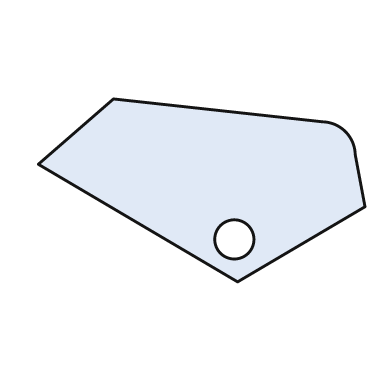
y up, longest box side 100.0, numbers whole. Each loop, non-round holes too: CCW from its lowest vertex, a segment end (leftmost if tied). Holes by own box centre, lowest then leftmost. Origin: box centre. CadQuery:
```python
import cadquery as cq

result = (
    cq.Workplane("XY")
    .moveTo(11.0, -28.0)
    .lineTo(50.0, -5.0)
    .lineTo(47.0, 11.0)
    .threePointArc((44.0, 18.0), (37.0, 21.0))
    .lineTo(-27.0, 28.0)
    .lineTo(-50.0, 8.0)
    .close()
    .moveTo(10.0, -15.0)
    .circle(6.0)
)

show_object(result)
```